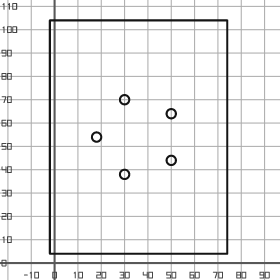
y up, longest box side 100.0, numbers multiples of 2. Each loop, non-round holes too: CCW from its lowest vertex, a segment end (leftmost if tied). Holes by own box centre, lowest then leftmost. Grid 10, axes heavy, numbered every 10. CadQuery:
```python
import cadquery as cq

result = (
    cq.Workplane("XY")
    .moveTo(-2.0, 4.0)
    .lineTo(74.0, 4.0)
    .lineTo(74.0, 104.0)
    .lineTo(-2.0, 104.0)
    .close()
    .moveTo(30.0, 38.0)
    .circle(2.0)
    .moveTo(50.0, 44.0)
    .circle(2.0)
    .moveTo(18.0, 54.0)
    .circle(2.0)
    .moveTo(50.0, 64.0)
    .circle(2.0)
    .moveTo(30.0, 70.0)
    .circle(2.0)
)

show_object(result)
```